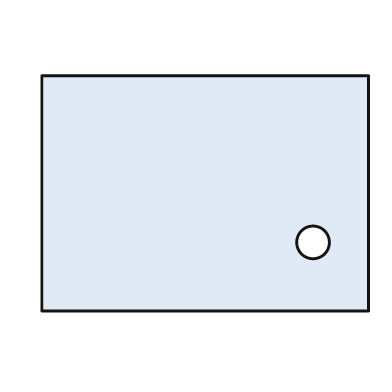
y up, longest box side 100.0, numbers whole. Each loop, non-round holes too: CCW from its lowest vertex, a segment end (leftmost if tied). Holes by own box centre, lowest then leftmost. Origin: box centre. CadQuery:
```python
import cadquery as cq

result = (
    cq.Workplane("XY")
    .moveTo(-50.0, -36.0)
    .lineTo(50.0, -36.0)
    .lineTo(50.0, 36.0)
    .lineTo(-50.0, 36.0)
    .close()
    .moveTo(33.0, -15.0)
    .circle(5.0)
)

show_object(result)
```